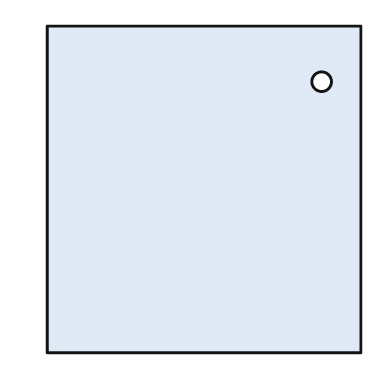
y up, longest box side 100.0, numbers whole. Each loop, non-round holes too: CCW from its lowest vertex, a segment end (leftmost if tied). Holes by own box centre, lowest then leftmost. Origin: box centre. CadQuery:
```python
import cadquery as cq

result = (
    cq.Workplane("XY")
    .moveTo(-48.0, -50.0)
    .lineTo(48.0, -50.0)
    .lineTo(48.0, 50.0)
    .lineTo(-48.0, 50.0)
    .close()
    .moveTo(36.0, 33.0)
    .circle(3.0)
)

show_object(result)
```